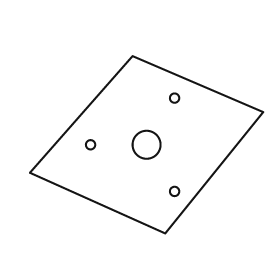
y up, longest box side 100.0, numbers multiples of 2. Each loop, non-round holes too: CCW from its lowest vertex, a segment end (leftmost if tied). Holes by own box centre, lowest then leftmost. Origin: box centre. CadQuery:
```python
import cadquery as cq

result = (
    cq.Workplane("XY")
    .moveTo(8.0, -38.0)
    .lineTo(50.0, 14.0)
    .lineTo(-6.0, 38.0)
    .lineTo(-50.0, -12.0)
    .close()
    .moveTo(12.0, -20.0)
    .circle(2.0)
    .moveTo(-24.0, 0.0)
    .circle(2.0)
    .moveTo(0.0, 0.0)
    .circle(6.0)
    .moveTo(12.0, 20.0)
    .circle(2.0)
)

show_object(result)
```